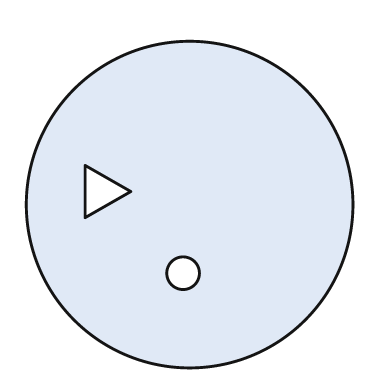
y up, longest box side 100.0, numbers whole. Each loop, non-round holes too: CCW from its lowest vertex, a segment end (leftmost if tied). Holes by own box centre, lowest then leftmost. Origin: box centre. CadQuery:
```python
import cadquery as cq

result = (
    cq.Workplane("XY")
    .moveTo(0.0, 0.0)
    .circle(50.0)
    .moveTo(-2.0, -21.0)
    .circle(5.0)
    .moveTo(-32.0, -4.0)
    .lineTo(-18.0, 4.0)
    .lineTo(-32.0, 12.0)
    .close()
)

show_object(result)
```